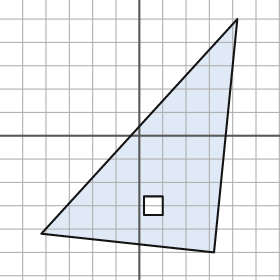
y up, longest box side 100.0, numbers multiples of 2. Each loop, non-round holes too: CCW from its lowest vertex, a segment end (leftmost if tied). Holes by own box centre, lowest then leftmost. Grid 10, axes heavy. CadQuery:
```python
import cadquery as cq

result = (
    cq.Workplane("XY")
    .moveTo(32.0, -50.0)
    .lineTo(42.0, 50.0)
    .lineTo(-42.0, -42.0)
    .close()
    .moveTo(2.0, -34.0)
    .lineTo(10.0, -34.0)
    .lineTo(10.0, -26.0)
    .lineTo(2.0, -26.0)
    .close()
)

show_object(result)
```